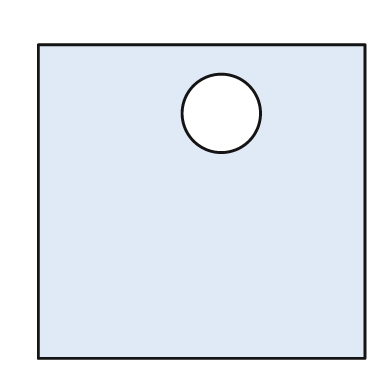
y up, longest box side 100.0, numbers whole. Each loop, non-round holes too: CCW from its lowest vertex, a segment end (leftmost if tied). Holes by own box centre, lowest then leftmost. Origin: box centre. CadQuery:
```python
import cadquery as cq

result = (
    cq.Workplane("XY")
    .moveTo(-50.0, -48.0)
    .lineTo(50.0, -48.0)
    .lineTo(50.0, 48.0)
    .lineTo(-50.0, 48.0)
    .close()
    .moveTo(6.0, 27.0)
    .circle(12.0)
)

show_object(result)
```